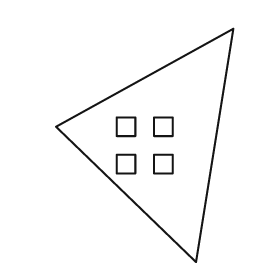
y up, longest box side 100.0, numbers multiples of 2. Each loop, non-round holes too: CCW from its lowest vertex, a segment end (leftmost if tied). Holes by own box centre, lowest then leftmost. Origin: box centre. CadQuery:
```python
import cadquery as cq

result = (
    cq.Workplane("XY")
    .moveTo(22.0, -50.0)
    .lineTo(38.0, 50.0)
    .lineTo(-38.0, 8.0)
    .close()
    .moveTo(-12.0, -12.0)
    .lineTo(-4.0, -12.0)
    .lineTo(-4.0, -4.0)
    .lineTo(-12.0, -4.0)
    .close()
    .moveTo(4.0, -12.0)
    .lineTo(12.0, -12.0)
    .lineTo(12.0, -4.0)
    .lineTo(4.0, -4.0)
    .close()
    .moveTo(-12.0, 4.0)
    .lineTo(-4.0, 4.0)
    .lineTo(-4.0, 12.0)
    .lineTo(-12.0, 12.0)
    .close()
    .moveTo(4.0, 4.0)
    .lineTo(12.0, 4.0)
    .lineTo(12.0, 12.0)
    .lineTo(4.0, 12.0)
    .close()
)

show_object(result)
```